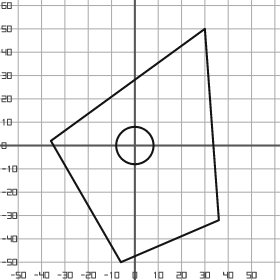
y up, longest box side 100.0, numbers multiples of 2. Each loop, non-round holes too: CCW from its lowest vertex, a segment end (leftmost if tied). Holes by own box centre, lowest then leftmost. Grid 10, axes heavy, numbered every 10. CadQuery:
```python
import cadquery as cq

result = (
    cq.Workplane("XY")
    .moveTo(-6.0, -50.0)
    .lineTo(36.0, -32.0)
    .lineTo(30.0, 50.0)
    .lineTo(-36.0, 2.0)
    .close()
    .moveTo(0.0, 0.0)
    .circle(8.0)
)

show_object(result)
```